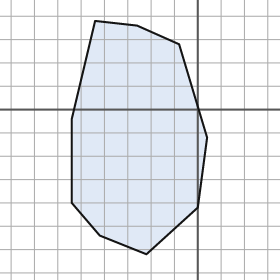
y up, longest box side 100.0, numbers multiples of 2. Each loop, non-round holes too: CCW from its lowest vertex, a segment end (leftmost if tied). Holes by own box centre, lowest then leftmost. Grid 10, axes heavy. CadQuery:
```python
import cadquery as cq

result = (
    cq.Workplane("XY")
    .moveTo(-22.0, -62.0)
    .lineTo(0.0, -42.0)
    .lineTo(4.0, -12.0)
    .lineTo(-8.0, 28.0)
    .lineTo(-26.0, 36.0)
    .lineTo(-44.0, 38.0)
    .lineTo(-54.0, -4.0)
    .lineTo(-54.0, -40.0)
    .lineTo(-42.0, -54.0)
    .close()
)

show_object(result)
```